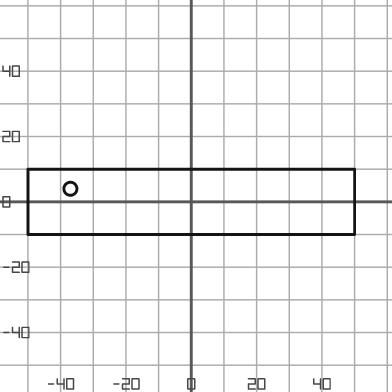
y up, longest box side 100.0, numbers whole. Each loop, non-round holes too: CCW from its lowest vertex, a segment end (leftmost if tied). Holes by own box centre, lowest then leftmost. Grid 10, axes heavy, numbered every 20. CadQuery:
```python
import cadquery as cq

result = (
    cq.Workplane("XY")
    .moveTo(-50.0, -10.0)
    .lineTo(50.0, -10.0)
    .lineTo(50.0, 10.0)
    .lineTo(-50.0, 10.0)
    .close()
    .moveTo(-37.0, 4.0)
    .circle(2.0)
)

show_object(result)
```